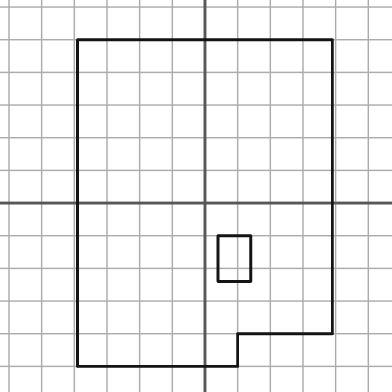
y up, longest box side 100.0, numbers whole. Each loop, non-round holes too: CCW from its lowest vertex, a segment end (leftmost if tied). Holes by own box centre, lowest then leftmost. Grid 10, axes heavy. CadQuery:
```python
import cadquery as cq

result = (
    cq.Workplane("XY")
    .moveTo(-39.0, -50.0)
    .lineTo(10.0, -50.0)
    .lineTo(10.0, -40.0)
    .lineTo(39.0, -40.0)
    .lineTo(39.0, 50.0)
    .lineTo(-39.0, 50.0)
    .close()
    .moveTo(4.0, -24.0)
    .lineTo(14.0, -24.0)
    .lineTo(14.0, -10.0)
    .lineTo(4.0, -10.0)
    .close()
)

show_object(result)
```